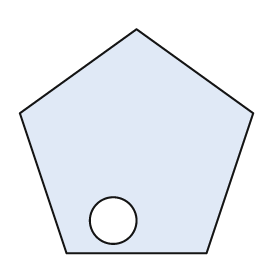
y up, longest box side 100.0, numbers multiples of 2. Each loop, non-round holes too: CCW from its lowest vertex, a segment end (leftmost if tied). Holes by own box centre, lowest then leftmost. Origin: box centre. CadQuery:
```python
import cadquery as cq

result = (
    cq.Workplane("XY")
    .moveTo(-30.0, -48.0)
    .lineTo(30.0, -48.0)
    .lineTo(50.0, 12.0)
    .lineTo(0.0, 48.0)
    .lineTo(-50.0, 12.0)
    .close()
    .moveTo(-10.0, -34.0)
    .circle(10.0)
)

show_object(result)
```